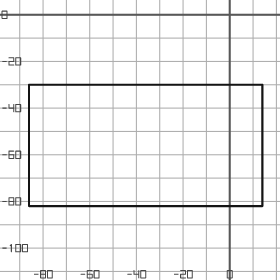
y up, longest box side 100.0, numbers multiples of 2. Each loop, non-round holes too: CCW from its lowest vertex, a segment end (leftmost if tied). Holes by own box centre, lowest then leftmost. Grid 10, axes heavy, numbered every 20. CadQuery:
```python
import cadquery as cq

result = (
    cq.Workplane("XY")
    .moveTo(-86.0, -82.0)
    .lineTo(14.0, -82.0)
    .lineTo(14.0, -30.0)
    .lineTo(-86.0, -30.0)
    .close()
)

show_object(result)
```